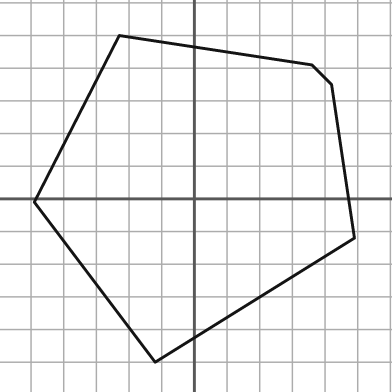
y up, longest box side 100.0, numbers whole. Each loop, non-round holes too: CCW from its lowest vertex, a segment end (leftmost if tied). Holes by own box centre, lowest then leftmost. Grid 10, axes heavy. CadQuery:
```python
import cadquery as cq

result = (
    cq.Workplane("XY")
    .moveTo(-12.0, -50.0)
    .lineTo(49.0, -12.0)
    .lineTo(42.0, 35.0)
    .lineTo(36.0, 41.0)
    .lineTo(-23.0, 50.0)
    .lineTo(-49.0, -1.0)
    .close()
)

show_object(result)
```